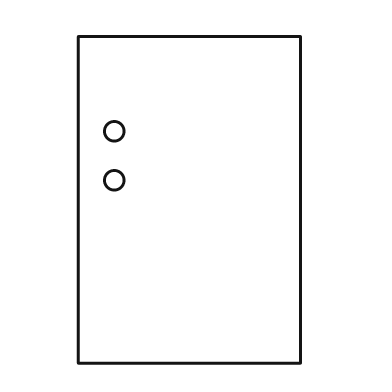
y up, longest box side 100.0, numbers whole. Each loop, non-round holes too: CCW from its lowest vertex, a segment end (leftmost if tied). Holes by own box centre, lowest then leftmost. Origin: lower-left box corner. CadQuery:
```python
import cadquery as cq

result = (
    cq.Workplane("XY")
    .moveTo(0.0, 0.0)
    .lineTo(68.0, 0.0)
    .lineTo(68.0, 100.0)
    .lineTo(0.0, 100.0)
    .close()
    .moveTo(11.0, 56.0)
    .circle(3.0)
    .moveTo(11.0, 71.0)
    .circle(3.0)
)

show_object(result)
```